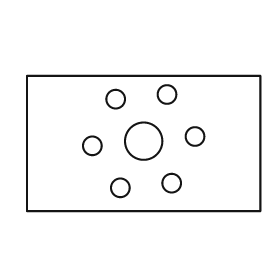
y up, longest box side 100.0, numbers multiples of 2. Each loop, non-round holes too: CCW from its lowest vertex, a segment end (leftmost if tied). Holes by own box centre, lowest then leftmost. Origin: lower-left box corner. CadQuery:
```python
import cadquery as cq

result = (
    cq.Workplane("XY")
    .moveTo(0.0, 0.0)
    .lineTo(100.0, 0.0)
    .lineTo(100.0, 58.0)
    .lineTo(0.0, 58.0)
    .close()
    .moveTo(40.0, 10.0)
    .circle(4.0)
    .moveTo(62.0, 12.0)
    .circle(4.0)
    .moveTo(28.0, 28.0)
    .circle(4.0)
    .moveTo(50.0, 30.0)
    .circle(8.0)
    .moveTo(72.0, 32.0)
    .circle(4.0)
    .moveTo(38.0, 48.0)
    .circle(4.0)
    .moveTo(60.0, 50.0)
    .circle(4.0)
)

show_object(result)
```